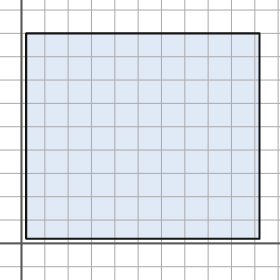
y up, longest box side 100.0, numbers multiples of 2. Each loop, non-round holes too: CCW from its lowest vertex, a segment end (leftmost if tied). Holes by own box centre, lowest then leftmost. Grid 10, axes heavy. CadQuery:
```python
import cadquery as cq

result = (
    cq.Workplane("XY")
    .moveTo(2.0, 2.0)
    .lineTo(102.0, 2.0)
    .lineTo(102.0, 90.0)
    .lineTo(2.0, 90.0)
    .close()
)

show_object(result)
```